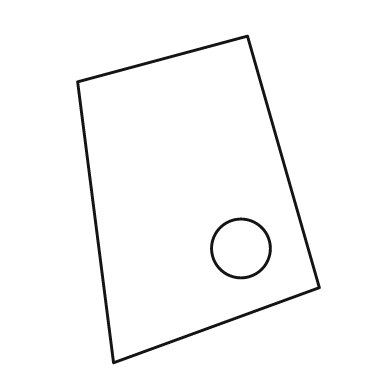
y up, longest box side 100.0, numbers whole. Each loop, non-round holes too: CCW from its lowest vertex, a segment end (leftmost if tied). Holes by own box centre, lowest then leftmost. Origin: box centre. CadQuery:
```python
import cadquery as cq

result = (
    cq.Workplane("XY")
    .moveTo(-26.0, -50.0)
    .lineTo(37.0, -27.0)
    .lineTo(15.0, 50.0)
    .lineTo(-37.0, 36.0)
    .close()
    .moveTo(13.0, -15.0)
    .circle(9.0)
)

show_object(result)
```